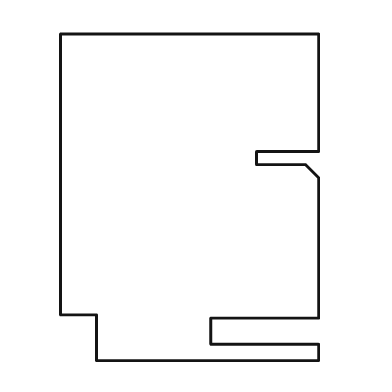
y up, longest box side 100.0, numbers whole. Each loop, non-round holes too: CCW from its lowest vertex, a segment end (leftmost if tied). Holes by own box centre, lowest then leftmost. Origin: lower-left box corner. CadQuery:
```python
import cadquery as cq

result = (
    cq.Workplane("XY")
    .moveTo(11.0, 0.0)
    .lineTo(79.0, 0.0)
    .lineTo(79.0, 5.0)
    .lineTo(46.0, 5.0)
    .lineTo(46.0, 13.0)
    .lineTo(79.0, 13.0)
    .lineTo(79.0, 56.0)
    .lineTo(75.0, 60.0)
    .lineTo(60.0, 60.0)
    .lineTo(60.0, 64.0)
    .lineTo(79.0, 64.0)
    .lineTo(79.0, 100.0)
    .lineTo(0.0, 100.0)
    .lineTo(0.0, 14.0)
    .lineTo(11.0, 14.0)
    .close()
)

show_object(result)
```